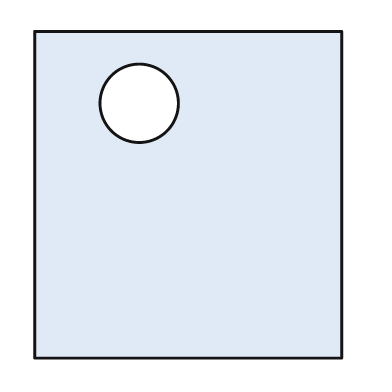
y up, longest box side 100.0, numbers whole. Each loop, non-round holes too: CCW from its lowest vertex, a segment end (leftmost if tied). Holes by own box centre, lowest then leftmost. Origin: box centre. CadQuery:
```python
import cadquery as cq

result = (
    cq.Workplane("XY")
    .moveTo(-47.0, -50.0)
    .lineTo(47.0, -50.0)
    .lineTo(47.0, 50.0)
    .lineTo(-47.0, 50.0)
    .close()
    .moveTo(-15.0, 28.0)
    .circle(12.0)
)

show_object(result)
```